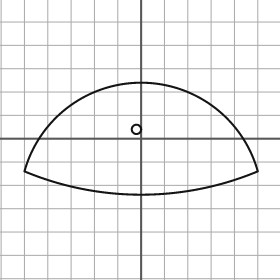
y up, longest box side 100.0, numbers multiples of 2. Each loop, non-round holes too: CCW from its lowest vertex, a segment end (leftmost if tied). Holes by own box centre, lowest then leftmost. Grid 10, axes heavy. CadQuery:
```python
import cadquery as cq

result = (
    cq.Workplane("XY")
    .moveTo(-50.0, -14.0)
    .threePointArc((0.0, -24.0), (50.0, -14.0))
    .threePointArc((0.0, 24.0), (-50.0, -14.0))
    .close()
    .moveTo(-2.0, 4.0)
    .circle(2.0)
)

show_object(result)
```